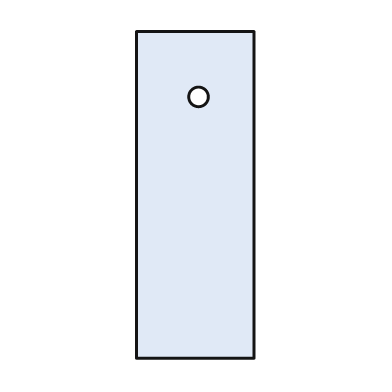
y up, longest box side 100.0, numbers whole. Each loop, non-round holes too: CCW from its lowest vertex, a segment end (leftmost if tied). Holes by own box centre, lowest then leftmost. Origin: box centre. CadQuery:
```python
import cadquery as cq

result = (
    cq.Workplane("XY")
    .moveTo(-18.0, -50.0)
    .lineTo(18.0, -50.0)
    .lineTo(18.0, 50.0)
    .lineTo(-18.0, 50.0)
    .close()
    .moveTo(1.0, 30.0)
    .circle(3.0)
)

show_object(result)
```